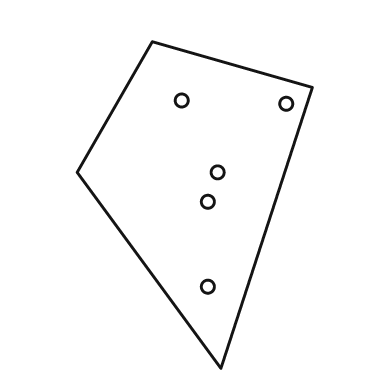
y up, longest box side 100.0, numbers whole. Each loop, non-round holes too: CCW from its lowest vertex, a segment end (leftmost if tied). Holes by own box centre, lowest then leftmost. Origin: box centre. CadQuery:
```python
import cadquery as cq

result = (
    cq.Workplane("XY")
    .moveTo(8.0, -50.0)
    .lineTo(36.0, 36.0)
    .lineTo(-13.0, 50.0)
    .lineTo(-36.0, 10.0)
    .close()
    .moveTo(4.0, -25.0)
    .circle(2.0)
    .moveTo(4.0, 1.0)
    .circle(2.0)
    .moveTo(7.0, 10.0)
    .circle(2.0)
    .moveTo(28.0, 31.0)
    .circle(2.0)
    .moveTo(-4.0, 32.0)
    .circle(2.0)
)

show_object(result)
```